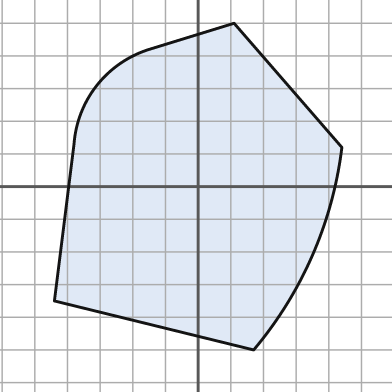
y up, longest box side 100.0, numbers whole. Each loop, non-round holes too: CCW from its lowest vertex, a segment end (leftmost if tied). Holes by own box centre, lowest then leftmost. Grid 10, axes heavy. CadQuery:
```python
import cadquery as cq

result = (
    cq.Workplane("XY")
    .moveTo(17.0, -50.0)
    .threePointArc((35.0, -21.0), (44.0, 12.0))
    .lineTo(11.0, 50.0)
    .lineTo(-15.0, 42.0)
    .threePointArc((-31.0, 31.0), (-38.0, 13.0))
    .lineTo(-44.0, -35.0)
    .close()
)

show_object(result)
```